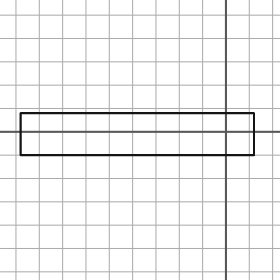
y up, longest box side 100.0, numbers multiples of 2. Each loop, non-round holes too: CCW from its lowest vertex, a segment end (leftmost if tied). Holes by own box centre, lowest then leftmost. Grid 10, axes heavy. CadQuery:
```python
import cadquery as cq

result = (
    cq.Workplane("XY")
    .moveTo(-88.0, -10.0)
    .lineTo(12.0, -10.0)
    .lineTo(12.0, 8.0)
    .lineTo(-88.0, 8.0)
    .close()
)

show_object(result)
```